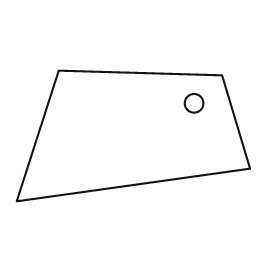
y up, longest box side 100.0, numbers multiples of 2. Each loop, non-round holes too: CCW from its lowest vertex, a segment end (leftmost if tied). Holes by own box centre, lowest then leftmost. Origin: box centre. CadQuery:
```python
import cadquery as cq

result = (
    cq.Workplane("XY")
    .moveTo(-50.0, -28.0)
    .lineTo(50.0, -14.0)
    .lineTo(38.0, 26.0)
    .lineTo(-32.0, 28.0)
    .close()
    .moveTo(26.0, 14.0)
    .circle(4.0)
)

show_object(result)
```